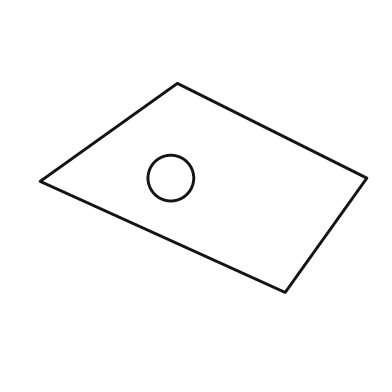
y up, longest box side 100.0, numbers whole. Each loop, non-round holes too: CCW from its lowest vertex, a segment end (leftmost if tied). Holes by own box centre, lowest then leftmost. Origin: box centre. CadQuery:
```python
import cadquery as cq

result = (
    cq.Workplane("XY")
    .moveTo(25.0, -32.0)
    .lineTo(50.0, 3.0)
    .lineTo(-8.0, 32.0)
    .lineTo(-50.0, 2.0)
    .close()
    .moveTo(-10.0, 3.0)
    .circle(7.0)
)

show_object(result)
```